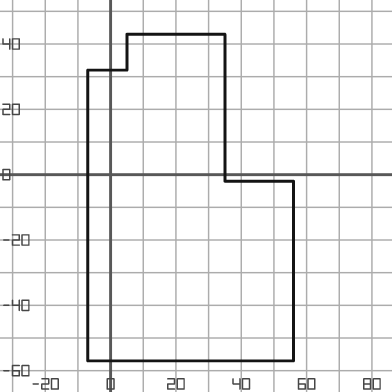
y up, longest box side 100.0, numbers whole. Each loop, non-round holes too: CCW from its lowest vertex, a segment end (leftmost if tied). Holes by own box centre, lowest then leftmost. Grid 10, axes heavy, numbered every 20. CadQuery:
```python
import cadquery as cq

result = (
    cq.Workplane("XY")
    .moveTo(-7.0, -57.0)
    .lineTo(56.0, -57.0)
    .lineTo(56.0, -2.0)
    .lineTo(35.0, -2.0)
    .lineTo(35.0, 43.0)
    .lineTo(5.0, 43.0)
    .lineTo(5.0, 32.0)
    .lineTo(-7.0, 32.0)
    .close()
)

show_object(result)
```